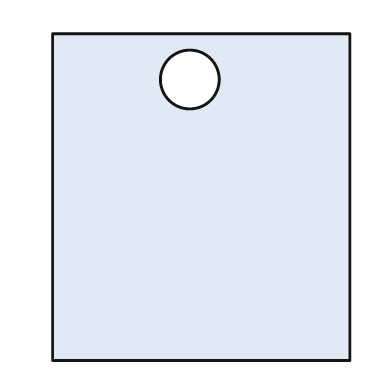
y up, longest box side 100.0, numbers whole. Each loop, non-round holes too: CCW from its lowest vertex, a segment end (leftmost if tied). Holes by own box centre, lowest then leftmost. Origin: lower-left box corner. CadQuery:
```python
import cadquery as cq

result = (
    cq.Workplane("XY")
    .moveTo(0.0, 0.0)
    .lineTo(91.0, 0.0)
    .lineTo(91.0, 100.0)
    .lineTo(0.0, 100.0)
    .close()
    .moveTo(42.0, 86.0)
    .circle(9.0)
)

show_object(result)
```